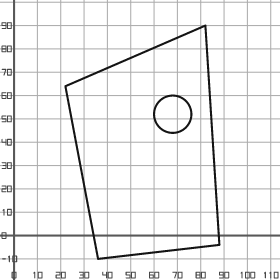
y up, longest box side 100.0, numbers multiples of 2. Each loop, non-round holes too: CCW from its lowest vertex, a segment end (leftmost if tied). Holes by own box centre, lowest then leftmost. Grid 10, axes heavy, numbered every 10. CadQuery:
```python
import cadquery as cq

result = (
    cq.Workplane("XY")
    .moveTo(36.0, -10.0)
    .lineTo(88.0, -4.0)
    .lineTo(82.0, 90.0)
    .lineTo(22.0, 64.0)
    .close()
    .moveTo(68.0, 52.0)
    .circle(8.0)
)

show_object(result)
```